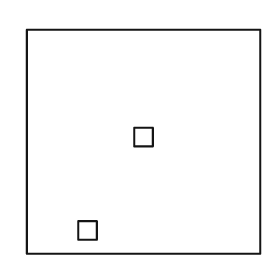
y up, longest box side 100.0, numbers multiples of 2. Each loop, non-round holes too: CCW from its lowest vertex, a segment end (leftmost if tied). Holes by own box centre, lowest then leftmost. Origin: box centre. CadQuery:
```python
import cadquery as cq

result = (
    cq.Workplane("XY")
    .moveTo(-50.0, -48.0)
    .lineTo(50.0, -48.0)
    .lineTo(50.0, 48.0)
    .lineTo(-50.0, 48.0)
    .close()
    .moveTo(-28.0, -42.0)
    .lineTo(-20.0, -42.0)
    .lineTo(-20.0, -34.0)
    .lineTo(-28.0, -34.0)
    .close()
    .moveTo(-4.0, -2.0)
    .lineTo(4.0, -2.0)
    .lineTo(4.0, 6.0)
    .lineTo(-4.0, 6.0)
    .close()
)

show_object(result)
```